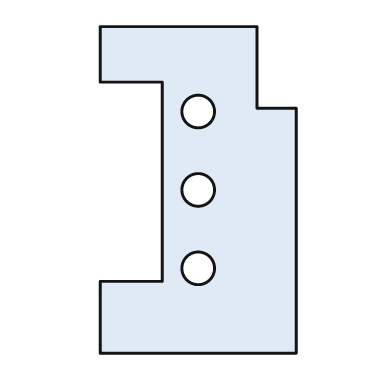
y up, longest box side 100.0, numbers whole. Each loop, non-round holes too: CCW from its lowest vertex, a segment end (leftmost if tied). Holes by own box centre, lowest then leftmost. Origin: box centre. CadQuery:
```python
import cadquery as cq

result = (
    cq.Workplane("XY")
    .moveTo(-30.0, -50.0)
    .lineTo(30.0, -50.0)
    .lineTo(30.0, 25.0)
    .lineTo(18.0, 25.0)
    .lineTo(18.0, 50.0)
    .lineTo(-30.0, 50.0)
    .lineTo(-30.0, 33.0)
    .lineTo(-11.0, 33.0)
    .lineTo(-11.0, -28.0)
    .lineTo(-30.0, -28.0)
    .close()
    .moveTo(0.0, -24.0)
    .circle(5.0)
    .moveTo(0.0, 0.0)
    .circle(5.0)
    .moveTo(0.0, 24.0)
    .circle(5.0)
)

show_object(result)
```